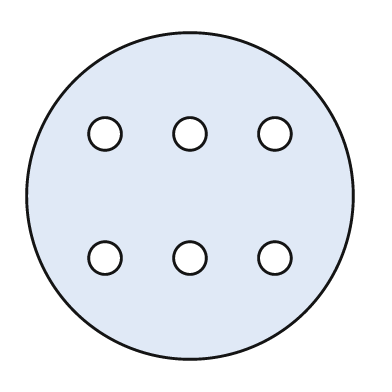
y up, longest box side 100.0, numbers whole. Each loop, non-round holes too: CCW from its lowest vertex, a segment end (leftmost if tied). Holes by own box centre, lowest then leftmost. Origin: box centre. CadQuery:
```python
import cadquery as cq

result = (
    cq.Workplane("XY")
    .moveTo(0.0, 0.0)
    .circle(50.0)
    .moveTo(-26.0, -19.0)
    .circle(5.0)
    .moveTo(0.0, -19.0)
    .circle(5.0)
    .moveTo(26.0, -19.0)
    .circle(5.0)
    .moveTo(-26.0, 19.0)
    .circle(5.0)
    .moveTo(0.0, 19.0)
    .circle(5.0)
    .moveTo(26.0, 19.0)
    .circle(5.0)
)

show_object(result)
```